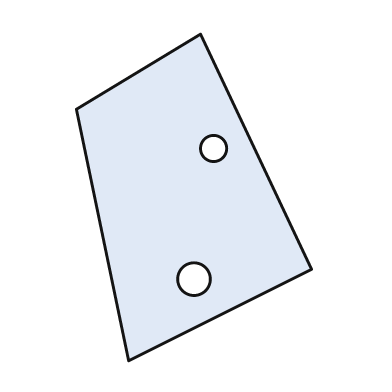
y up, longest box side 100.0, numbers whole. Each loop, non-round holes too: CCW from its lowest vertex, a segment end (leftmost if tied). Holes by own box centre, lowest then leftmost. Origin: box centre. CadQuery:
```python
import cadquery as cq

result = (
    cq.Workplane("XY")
    .moveTo(-20.0, -50.0)
    .lineTo(36.0, -22.0)
    .lineTo(2.0, 50.0)
    .lineTo(-36.0, 27.0)
    .close()
    .moveTo(0.0, -25.0)
    .circle(5.0)
    .moveTo(6.0, 15.0)
    .circle(4.0)
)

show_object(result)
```